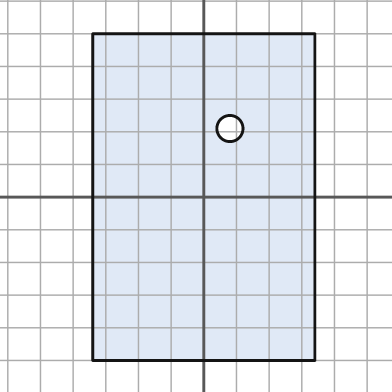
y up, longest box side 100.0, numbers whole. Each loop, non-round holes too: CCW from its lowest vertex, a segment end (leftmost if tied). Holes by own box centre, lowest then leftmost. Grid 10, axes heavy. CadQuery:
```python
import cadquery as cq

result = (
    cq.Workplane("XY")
    .moveTo(-34.0, -50.0)
    .lineTo(34.0, -50.0)
    .lineTo(34.0, 50.0)
    .lineTo(-34.0, 50.0)
    .close()
    .moveTo(8.0, 21.0)
    .circle(4.0)
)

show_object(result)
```